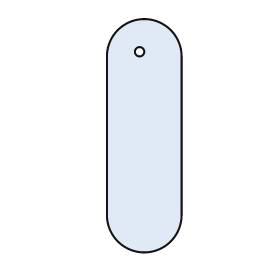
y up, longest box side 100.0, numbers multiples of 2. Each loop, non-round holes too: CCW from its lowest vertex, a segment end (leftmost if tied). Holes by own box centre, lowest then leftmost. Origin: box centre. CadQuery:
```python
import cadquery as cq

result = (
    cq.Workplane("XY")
    .moveTo(-16.0, -34.0)
    .threePointArc((0.0, -50.0), (16.0, -34.0))
    .lineTo(16.0, 34.0)
    .threePointArc((0.0, 50.0), (-16.0, 34.0))
    .close()
    .moveTo(-2.0, 36.0)
    .circle(2.0)
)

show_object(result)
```